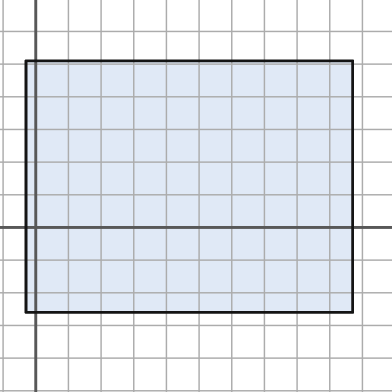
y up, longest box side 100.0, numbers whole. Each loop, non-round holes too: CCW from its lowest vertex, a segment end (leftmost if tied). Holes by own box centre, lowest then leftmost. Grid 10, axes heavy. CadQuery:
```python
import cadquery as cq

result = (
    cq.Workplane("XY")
    .moveTo(-3.0, -26.0)
    .lineTo(97.0, -26.0)
    .lineTo(97.0, 51.0)
    .lineTo(-3.0, 51.0)
    .close()
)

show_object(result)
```